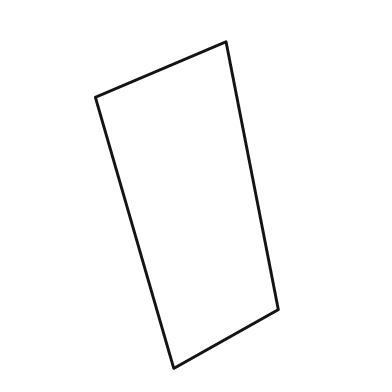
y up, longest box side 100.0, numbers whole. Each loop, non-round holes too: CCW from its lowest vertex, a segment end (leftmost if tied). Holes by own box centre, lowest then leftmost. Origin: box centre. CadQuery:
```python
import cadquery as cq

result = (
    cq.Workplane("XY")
    .moveTo(-4.0, -50.0)
    .lineTo(28.0, -32.0)
    .lineTo(12.0, 50.0)
    .lineTo(-28.0, 33.0)
    .close()
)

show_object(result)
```